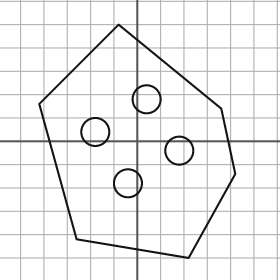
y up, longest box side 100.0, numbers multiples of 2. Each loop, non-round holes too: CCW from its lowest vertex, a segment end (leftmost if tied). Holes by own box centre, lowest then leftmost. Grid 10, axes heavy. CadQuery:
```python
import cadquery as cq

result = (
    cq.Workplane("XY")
    .moveTo(22.0, -50.0)
    .lineTo(42.0, -14.0)
    .lineTo(36.0, 14.0)
    .lineTo(-8.0, 50.0)
    .lineTo(-42.0, 16.0)
    .lineTo(-26.0, -42.0)
    .close()
    .moveTo(-4.0, -18.0)
    .circle(6.0)
    .moveTo(18.0, -4.0)
    .circle(6.0)
    .moveTo(-18.0, 4.0)
    .circle(6.0)
    .moveTo(4.0, 18.0)
    .circle(6.0)
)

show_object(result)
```